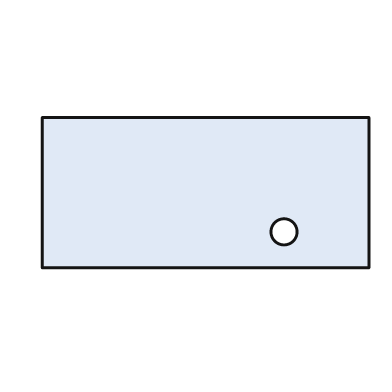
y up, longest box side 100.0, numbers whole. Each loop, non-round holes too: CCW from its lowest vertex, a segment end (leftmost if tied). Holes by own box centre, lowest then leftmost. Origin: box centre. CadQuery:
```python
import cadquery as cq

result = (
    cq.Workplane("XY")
    .moveTo(-50.0, -23.0)
    .lineTo(50.0, -23.0)
    .lineTo(50.0, 23.0)
    .lineTo(-50.0, 23.0)
    .close()
    .moveTo(24.0, -12.0)
    .circle(4.0)
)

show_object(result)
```